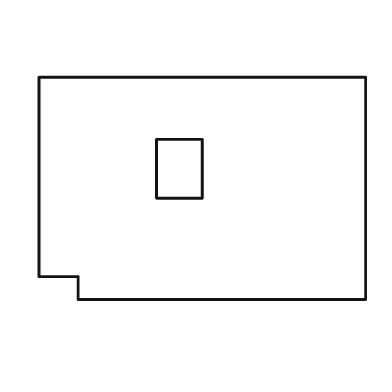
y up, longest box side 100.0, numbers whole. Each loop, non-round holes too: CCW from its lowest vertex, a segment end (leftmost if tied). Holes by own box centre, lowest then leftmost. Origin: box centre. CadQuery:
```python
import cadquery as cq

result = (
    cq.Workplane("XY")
    .moveTo(-38.0, -34.0)
    .lineTo(50.0, -34.0)
    .lineTo(50.0, 34.0)
    .lineTo(-50.0, 34.0)
    .lineTo(-50.0, -27.0)
    .lineTo(-38.0, -27.0)
    .close()
    .moveTo(-14.0, -3.0)
    .lineTo(0.0, -3.0)
    .lineTo(0.0, 15.0)
    .lineTo(-14.0, 15.0)
    .close()
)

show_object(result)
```